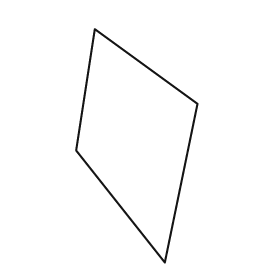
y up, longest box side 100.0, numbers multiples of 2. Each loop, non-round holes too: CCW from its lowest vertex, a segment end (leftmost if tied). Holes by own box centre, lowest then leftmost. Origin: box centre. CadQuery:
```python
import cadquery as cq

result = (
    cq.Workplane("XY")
    .moveTo(12.0, -50.0)
    .lineTo(26.0, 18.0)
    .lineTo(-18.0, 50.0)
    .lineTo(-26.0, -2.0)
    .close()
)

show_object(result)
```